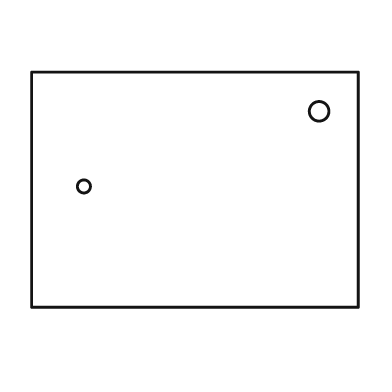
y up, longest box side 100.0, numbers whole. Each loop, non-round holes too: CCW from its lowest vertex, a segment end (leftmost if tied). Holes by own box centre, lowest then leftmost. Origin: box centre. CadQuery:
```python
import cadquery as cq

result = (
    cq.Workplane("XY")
    .moveTo(-50.0, -36.0)
    .lineTo(50.0, -36.0)
    .lineTo(50.0, 36.0)
    .lineTo(-50.0, 36.0)
    .close()
    .moveTo(-34.0, 1.0)
    .circle(2.0)
    .moveTo(38.0, 24.0)
    .circle(3.0)
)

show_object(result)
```